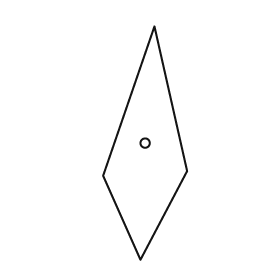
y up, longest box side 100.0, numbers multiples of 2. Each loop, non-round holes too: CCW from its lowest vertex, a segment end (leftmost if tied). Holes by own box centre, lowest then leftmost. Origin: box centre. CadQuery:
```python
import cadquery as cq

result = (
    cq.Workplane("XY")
    .moveTo(-2.0, -50.0)
    .lineTo(18.0, -12.0)
    .lineTo(4.0, 50.0)
    .lineTo(-18.0, -14.0)
    .close()
    .moveTo(0.0, 0.0)
    .circle(2.0)
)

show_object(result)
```